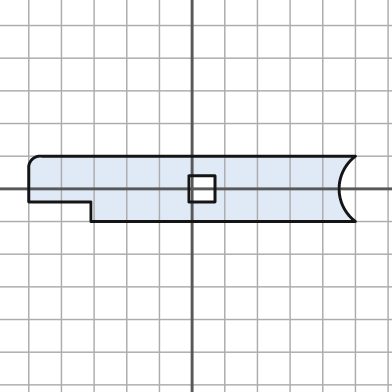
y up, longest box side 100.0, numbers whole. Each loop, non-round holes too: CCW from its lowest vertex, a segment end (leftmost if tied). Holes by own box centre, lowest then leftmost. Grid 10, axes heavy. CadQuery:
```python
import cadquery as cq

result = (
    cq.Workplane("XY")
    .moveTo(-31.0, -10.0)
    .lineTo(50.0, -10.0)
    .threePointArc((45.0, 0.0), (50.0, 10.0))
    .lineTo(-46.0, 10.0)
    .threePointArc((-49.0, 9.0), (-50.0, 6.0))
    .lineTo(-50.0, -4.0)
    .lineTo(-31.0, -4.0)
    .close()
    .moveTo(-1.0, -4.0)
    .lineTo(7.0, -4.0)
    .lineTo(7.0, 4.0)
    .lineTo(-1.0, 4.0)
    .close()
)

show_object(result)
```